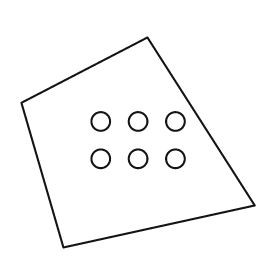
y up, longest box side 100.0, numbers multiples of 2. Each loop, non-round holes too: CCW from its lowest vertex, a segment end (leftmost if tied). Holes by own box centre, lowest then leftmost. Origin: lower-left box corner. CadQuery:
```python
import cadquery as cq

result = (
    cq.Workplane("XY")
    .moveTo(18.0, 0.0)
    .lineTo(100.0, 18.0)
    .lineTo(54.0, 90.0)
    .lineTo(0.0, 62.0)
    .close()
    .moveTo(34.0, 38.0)
    .circle(4.0)
    .moveTo(50.0, 38.0)
    .circle(4.0)
    .moveTo(66.0, 38.0)
    .circle(4.0)
    .moveTo(34.0, 54.0)
    .circle(4.0)
    .moveTo(50.0, 54.0)
    .circle(4.0)
    .moveTo(66.0, 54.0)
    .circle(4.0)
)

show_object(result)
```